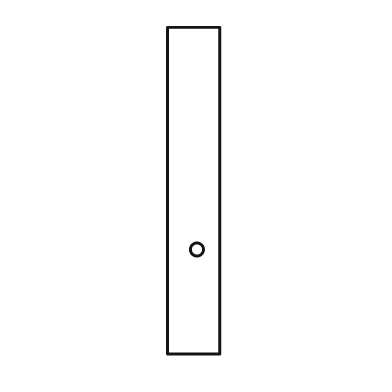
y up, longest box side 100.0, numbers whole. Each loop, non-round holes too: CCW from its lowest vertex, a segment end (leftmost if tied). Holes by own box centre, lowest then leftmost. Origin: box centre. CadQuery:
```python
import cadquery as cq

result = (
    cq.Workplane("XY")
    .moveTo(-8.0, -50.0)
    .lineTo(8.0, -50.0)
    .lineTo(8.0, 50.0)
    .lineTo(-8.0, 50.0)
    .close()
    .moveTo(1.0, -18.0)
    .circle(2.0)
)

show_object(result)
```